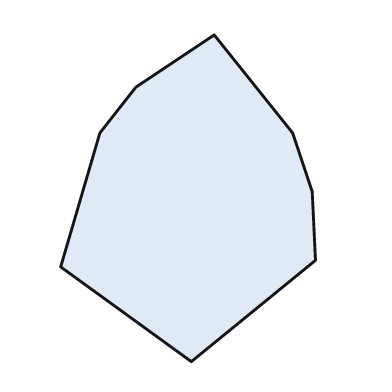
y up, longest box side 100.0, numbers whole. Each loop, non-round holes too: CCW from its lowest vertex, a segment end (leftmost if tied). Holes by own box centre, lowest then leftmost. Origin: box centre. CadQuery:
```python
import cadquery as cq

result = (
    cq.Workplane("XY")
    .moveTo(1.0, -50.0)
    .lineTo(39.0, -19.0)
    .lineTo(38.0, 2.0)
    .lineTo(32.0, 20.0)
    .lineTo(8.0, 50.0)
    .lineTo(-16.0, 34.0)
    .lineTo(-27.0, 20.0)
    .lineTo(-39.0, -21.0)
    .close()
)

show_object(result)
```